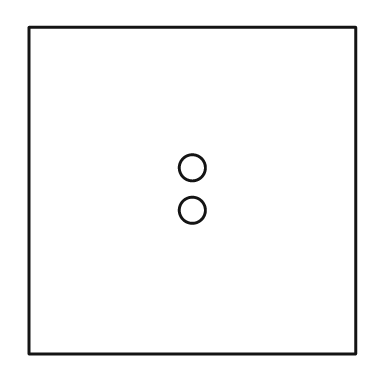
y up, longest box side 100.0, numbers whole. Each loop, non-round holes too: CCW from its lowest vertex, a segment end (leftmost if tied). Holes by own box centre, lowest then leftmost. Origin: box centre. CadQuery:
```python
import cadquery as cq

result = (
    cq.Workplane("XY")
    .moveTo(-50.0, -50.0)
    .lineTo(50.0, -50.0)
    .lineTo(50.0, 50.0)
    .lineTo(-50.0, 50.0)
    .close()
    .moveTo(0.0, -6.0)
    .circle(4.0)
    .moveTo(0.0, 7.0)
    .circle(4.0)
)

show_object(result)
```